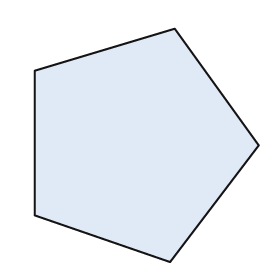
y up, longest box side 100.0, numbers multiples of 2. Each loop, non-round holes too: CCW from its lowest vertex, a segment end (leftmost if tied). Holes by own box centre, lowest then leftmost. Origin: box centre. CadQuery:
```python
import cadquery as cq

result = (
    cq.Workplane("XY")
    .moveTo(10.0, -50.0)
    .lineTo(48.0, 0.0)
    .lineTo(12.0, 50.0)
    .lineTo(-48.0, 32.0)
    .lineTo(-48.0, -30.0)
    .close()
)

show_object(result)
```